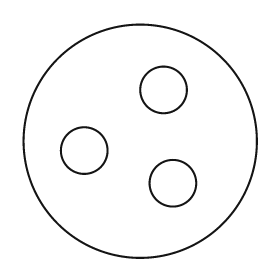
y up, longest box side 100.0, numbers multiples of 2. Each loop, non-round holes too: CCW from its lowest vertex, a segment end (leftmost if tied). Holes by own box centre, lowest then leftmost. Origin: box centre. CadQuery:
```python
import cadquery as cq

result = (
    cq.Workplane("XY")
    .moveTo(0.0, 0.0)
    .circle(50.0)
    .moveTo(14.0, -18.0)
    .circle(10.0)
    .moveTo(-24.0, -4.0)
    .circle(10.0)
    .moveTo(10.0, 22.0)
    .circle(10.0)
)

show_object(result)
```